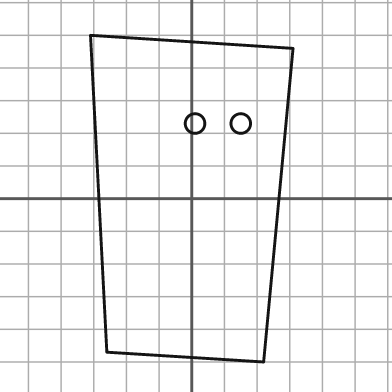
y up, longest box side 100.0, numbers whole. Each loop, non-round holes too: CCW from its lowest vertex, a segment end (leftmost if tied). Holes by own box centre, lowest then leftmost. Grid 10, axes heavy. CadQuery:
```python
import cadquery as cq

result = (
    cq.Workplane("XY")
    .moveTo(22.0, -50.0)
    .lineTo(31.0, 46.0)
    .lineTo(-31.0, 50.0)
    .lineTo(-26.0, -47.0)
    .close()
    .moveTo(1.0, 23.0)
    .circle(3.0)
    .moveTo(15.0, 23.0)
    .circle(3.0)
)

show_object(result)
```